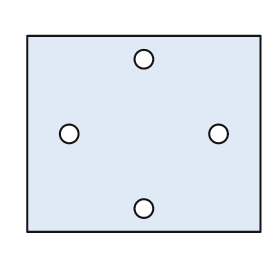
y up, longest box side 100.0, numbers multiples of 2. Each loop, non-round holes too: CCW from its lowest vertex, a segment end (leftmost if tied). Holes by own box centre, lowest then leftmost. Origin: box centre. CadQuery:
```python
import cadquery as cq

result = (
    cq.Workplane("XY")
    .moveTo(-50.0, -42.0)
    .lineTo(50.0, -42.0)
    .lineTo(50.0, 42.0)
    .lineTo(-50.0, 42.0)
    .close()
    .moveTo(0.0, -32.0)
    .circle(4.0)
    .moveTo(-32.0, 0.0)
    .circle(4.0)
    .moveTo(32.0, 0.0)
    .circle(4.0)
    .moveTo(0.0, 32.0)
    .circle(4.0)
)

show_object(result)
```